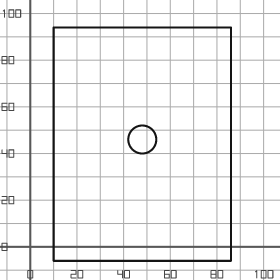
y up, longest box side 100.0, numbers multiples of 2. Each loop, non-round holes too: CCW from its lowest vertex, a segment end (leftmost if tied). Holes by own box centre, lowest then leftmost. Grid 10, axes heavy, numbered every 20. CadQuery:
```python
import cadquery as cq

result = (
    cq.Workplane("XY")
    .moveTo(10.0, -6.0)
    .lineTo(86.0, -6.0)
    .lineTo(86.0, 94.0)
    .lineTo(10.0, 94.0)
    .close()
    .moveTo(48.0, 46.0)
    .circle(6.0)
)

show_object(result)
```